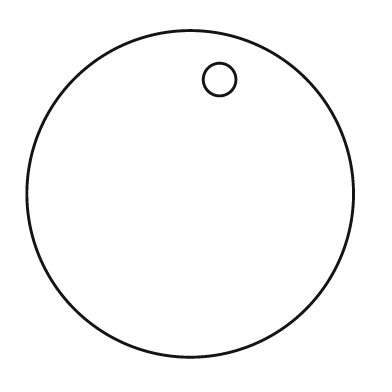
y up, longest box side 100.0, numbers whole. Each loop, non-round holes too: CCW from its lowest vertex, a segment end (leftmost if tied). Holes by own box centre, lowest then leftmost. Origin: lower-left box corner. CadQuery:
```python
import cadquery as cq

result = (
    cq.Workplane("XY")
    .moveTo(50.0, 50.0)
    .circle(50.0)
    .moveTo(59.0, 85.0)
    .circle(5.0)
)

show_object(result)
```